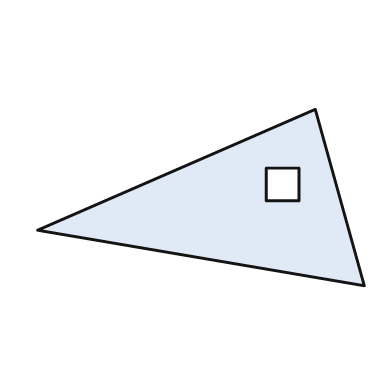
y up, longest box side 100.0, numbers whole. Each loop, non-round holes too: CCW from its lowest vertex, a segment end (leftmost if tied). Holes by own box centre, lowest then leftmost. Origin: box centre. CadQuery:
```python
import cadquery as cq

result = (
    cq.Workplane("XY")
    .moveTo(50.0, -27.0)
    .lineTo(35.0, 27.0)
    .lineTo(-50.0, -10.0)
    .close()
    .moveTo(20.0, -1.0)
    .lineTo(30.0, -1.0)
    .lineTo(30.0, 9.0)
    .lineTo(20.0, 9.0)
    .close()
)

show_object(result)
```